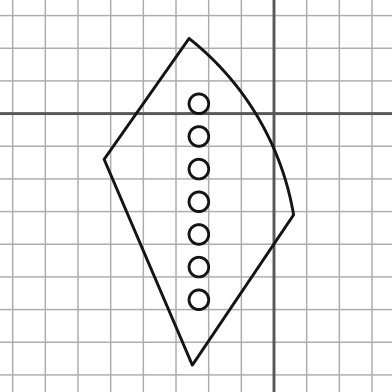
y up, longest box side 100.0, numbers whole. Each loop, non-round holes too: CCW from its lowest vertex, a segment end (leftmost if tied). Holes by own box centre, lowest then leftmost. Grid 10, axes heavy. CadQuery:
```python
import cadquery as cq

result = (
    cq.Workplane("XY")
    .moveTo(-25.0, -77.0)
    .lineTo(6.0, -31.0)
    .threePointArc((-5.0, -1.0), (-26.0, 23.0))
    .lineTo(-52.0, -14.0)
    .close()
    .moveTo(-23.0, -57.0)
    .circle(3.0)
    .moveTo(-23.0, -47.0)
    .circle(3.0)
    .moveTo(-23.0, -37.0)
    .circle(3.0)
    .moveTo(-23.0, -27.0)
    .circle(3.0)
    .moveTo(-23.0, -17.0)
    .circle(3.0)
    .moveTo(-23.0, -7.0)
    .circle(3.0)
    .moveTo(-23.0, 3.0)
    .circle(3.0)
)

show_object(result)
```